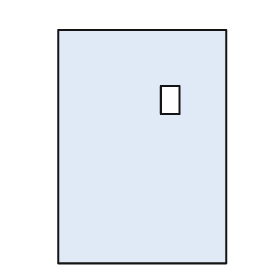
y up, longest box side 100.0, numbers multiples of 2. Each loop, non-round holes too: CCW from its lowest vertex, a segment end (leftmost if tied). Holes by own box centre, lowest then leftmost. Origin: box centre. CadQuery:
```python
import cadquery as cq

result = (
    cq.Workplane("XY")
    .moveTo(-36.0, -50.0)
    .lineTo(36.0, -50.0)
    .lineTo(36.0, 50.0)
    .lineTo(-36.0, 50.0)
    .close()
    .moveTo(8.0, 14.0)
    .lineTo(16.0, 14.0)
    .lineTo(16.0, 26.0)
    .lineTo(8.0, 26.0)
    .close()
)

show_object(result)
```